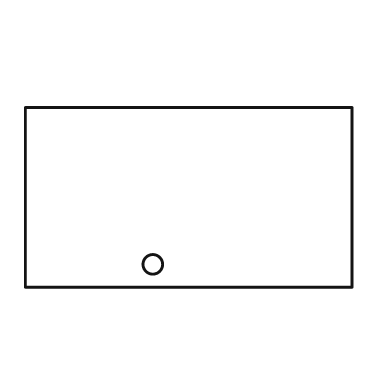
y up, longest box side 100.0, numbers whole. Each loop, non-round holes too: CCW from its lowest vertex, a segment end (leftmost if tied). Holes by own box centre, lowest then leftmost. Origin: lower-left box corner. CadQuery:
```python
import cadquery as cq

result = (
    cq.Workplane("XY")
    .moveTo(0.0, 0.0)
    .lineTo(100.0, 0.0)
    .lineTo(100.0, 55.0)
    .lineTo(0.0, 55.0)
    .close()
    .moveTo(39.0, 7.0)
    .circle(3.0)
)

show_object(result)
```